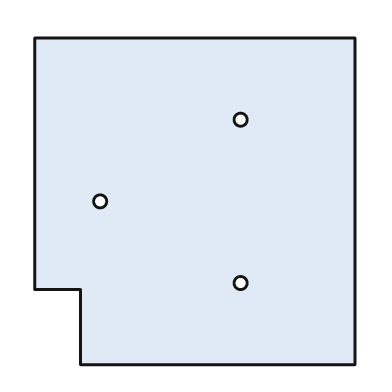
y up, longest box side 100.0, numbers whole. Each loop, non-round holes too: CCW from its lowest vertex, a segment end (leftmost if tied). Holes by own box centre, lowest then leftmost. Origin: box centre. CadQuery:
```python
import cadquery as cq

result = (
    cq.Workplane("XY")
    .moveTo(-35.0, -50.0)
    .lineTo(49.0, -50.0)
    .lineTo(49.0, 50.0)
    .lineTo(-49.0, 50.0)
    .lineTo(-49.0, -27.0)
    .lineTo(-35.0, -27.0)
    .close()
    .moveTo(14.0, -25.0)
    .circle(2.0)
    .moveTo(-29.0, 0.0)
    .circle(2.0)
    .moveTo(14.0, 25.0)
    .circle(2.0)
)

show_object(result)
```